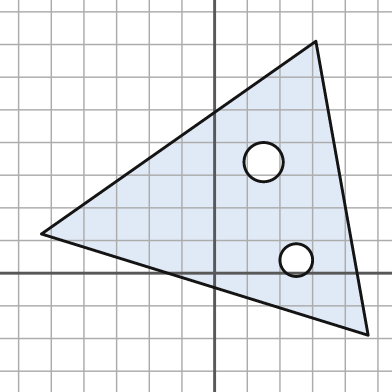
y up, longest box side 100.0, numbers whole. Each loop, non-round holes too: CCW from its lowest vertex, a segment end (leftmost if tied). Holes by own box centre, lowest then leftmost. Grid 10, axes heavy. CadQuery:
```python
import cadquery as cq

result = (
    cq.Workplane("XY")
    .moveTo(47.0, -19.0)
    .lineTo(31.0, 71.0)
    .lineTo(-53.0, 12.0)
    .close()
    .moveTo(25.0, 4.0)
    .circle(5.0)
    .moveTo(15.0, 34.0)
    .circle(6.0)
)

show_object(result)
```